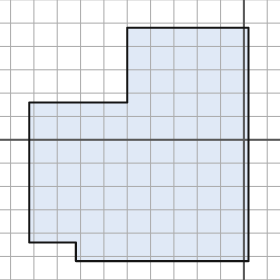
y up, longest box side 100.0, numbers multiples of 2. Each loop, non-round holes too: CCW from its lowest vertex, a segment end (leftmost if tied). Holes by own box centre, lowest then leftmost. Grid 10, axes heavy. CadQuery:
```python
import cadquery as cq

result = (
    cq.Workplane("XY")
    .moveTo(-72.0, -52.0)
    .lineTo(2.0, -52.0)
    .lineTo(2.0, 48.0)
    .lineTo(-50.0, 48.0)
    .lineTo(-50.0, 16.0)
    .lineTo(-92.0, 16.0)
    .lineTo(-92.0, -44.0)
    .lineTo(-72.0, -44.0)
    .close()
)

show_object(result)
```